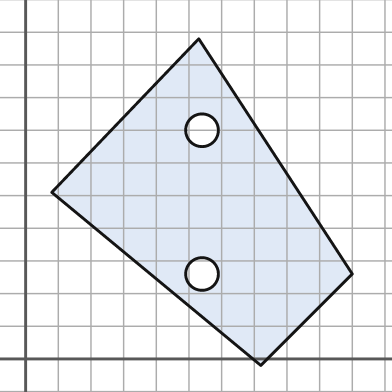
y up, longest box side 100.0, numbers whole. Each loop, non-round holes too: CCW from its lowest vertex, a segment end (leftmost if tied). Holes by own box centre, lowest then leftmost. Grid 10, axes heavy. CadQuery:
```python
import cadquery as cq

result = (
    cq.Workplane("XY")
    .moveTo(72.0, -2.0)
    .lineTo(100.0, 26.0)
    .lineTo(53.0, 98.0)
    .lineTo(8.0, 51.0)
    .close()
    .moveTo(54.0, 26.0)
    .circle(5.0)
    .moveTo(54.0, 70.0)
    .circle(5.0)
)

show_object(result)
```